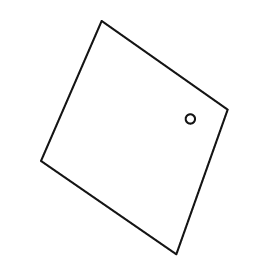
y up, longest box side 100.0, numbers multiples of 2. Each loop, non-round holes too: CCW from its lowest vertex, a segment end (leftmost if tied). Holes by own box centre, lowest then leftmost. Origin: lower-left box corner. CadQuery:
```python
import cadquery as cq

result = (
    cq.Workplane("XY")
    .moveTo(58.0, 0.0)
    .lineTo(80.0, 62.0)
    .lineTo(26.0, 100.0)
    .lineTo(0.0, 40.0)
    .close()
    .moveTo(64.0, 58.0)
    .circle(2.0)
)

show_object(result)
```